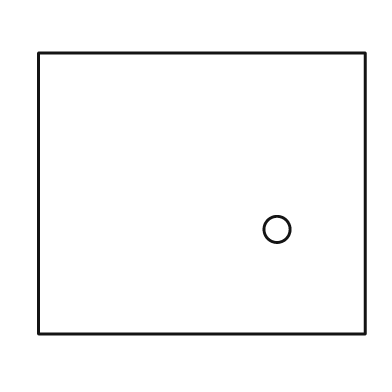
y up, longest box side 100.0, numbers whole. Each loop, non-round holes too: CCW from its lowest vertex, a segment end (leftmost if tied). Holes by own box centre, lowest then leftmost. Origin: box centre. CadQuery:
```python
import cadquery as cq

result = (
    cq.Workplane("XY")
    .moveTo(-50.0, -43.0)
    .lineTo(50.0, -43.0)
    .lineTo(50.0, 43.0)
    .lineTo(-50.0, 43.0)
    .close()
    .moveTo(23.0, -11.0)
    .circle(4.0)
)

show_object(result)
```